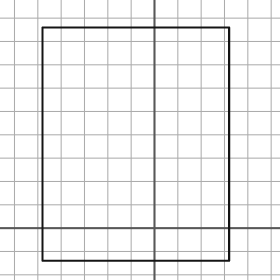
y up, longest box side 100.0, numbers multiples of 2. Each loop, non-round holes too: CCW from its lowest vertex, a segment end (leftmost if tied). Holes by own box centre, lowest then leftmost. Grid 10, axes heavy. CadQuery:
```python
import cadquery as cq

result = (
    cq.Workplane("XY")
    .moveTo(-48.0, -14.0)
    .lineTo(32.0, -14.0)
    .lineTo(32.0, 86.0)
    .lineTo(-48.0, 86.0)
    .close()
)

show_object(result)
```